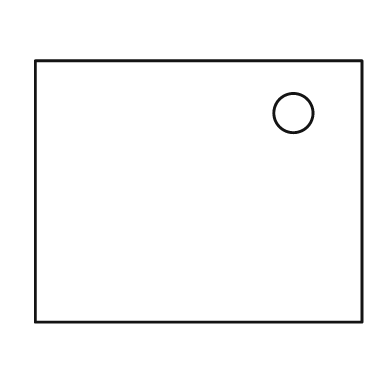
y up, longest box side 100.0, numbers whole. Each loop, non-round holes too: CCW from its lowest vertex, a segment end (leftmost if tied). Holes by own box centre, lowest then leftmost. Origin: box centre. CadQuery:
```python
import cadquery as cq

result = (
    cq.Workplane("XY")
    .moveTo(-50.0, -40.0)
    .lineTo(50.0, -40.0)
    .lineTo(50.0, 40.0)
    .lineTo(-50.0, 40.0)
    .close()
    .moveTo(29.0, 24.0)
    .circle(6.0)
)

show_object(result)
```